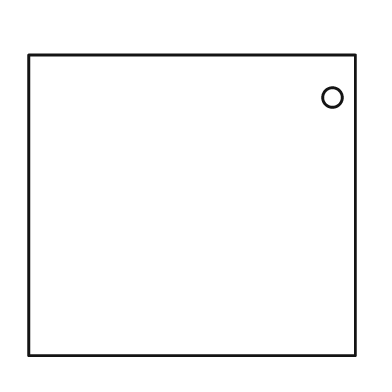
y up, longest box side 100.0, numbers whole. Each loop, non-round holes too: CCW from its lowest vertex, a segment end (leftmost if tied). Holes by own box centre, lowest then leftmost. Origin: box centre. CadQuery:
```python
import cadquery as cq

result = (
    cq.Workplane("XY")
    .moveTo(-50.0, -46.0)
    .lineTo(50.0, -46.0)
    .lineTo(50.0, 46.0)
    .lineTo(-50.0, 46.0)
    .close()
    .moveTo(43.0, 33.0)
    .circle(3.0)
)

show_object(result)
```